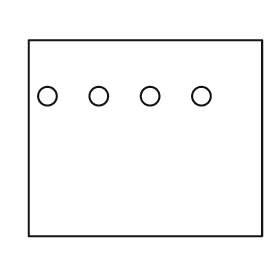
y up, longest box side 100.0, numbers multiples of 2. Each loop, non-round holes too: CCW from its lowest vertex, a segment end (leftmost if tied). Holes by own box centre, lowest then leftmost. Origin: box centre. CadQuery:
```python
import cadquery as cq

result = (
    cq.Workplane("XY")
    .moveTo(-50.0, -42.0)
    .lineTo(50.0, -42.0)
    .lineTo(50.0, 42.0)
    .lineTo(-50.0, 42.0)
    .close()
    .moveTo(-42.0, 18.0)
    .circle(4.0)
    .moveTo(-20.0, 18.0)
    .circle(4.0)
    .moveTo(2.0, 18.0)
    .circle(4.0)
    .moveTo(24.0, 18.0)
    .circle(4.0)
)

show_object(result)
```